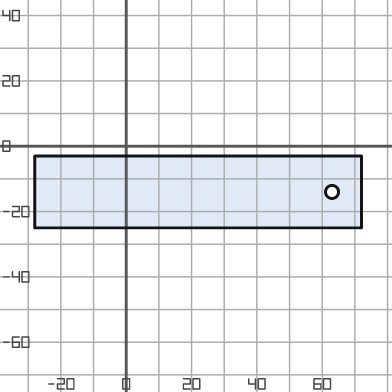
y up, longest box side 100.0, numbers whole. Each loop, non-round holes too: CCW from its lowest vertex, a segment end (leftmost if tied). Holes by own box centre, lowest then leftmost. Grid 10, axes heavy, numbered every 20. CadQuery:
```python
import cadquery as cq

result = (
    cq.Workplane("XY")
    .moveTo(-28.0, -25.0)
    .lineTo(72.0, -25.0)
    .lineTo(72.0, -3.0)
    .lineTo(-28.0, -3.0)
    .close()
    .moveTo(63.0, -14.0)
    .circle(2.0)
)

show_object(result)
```